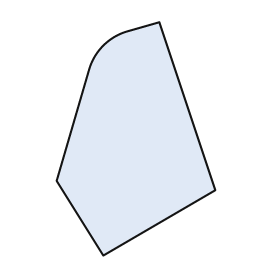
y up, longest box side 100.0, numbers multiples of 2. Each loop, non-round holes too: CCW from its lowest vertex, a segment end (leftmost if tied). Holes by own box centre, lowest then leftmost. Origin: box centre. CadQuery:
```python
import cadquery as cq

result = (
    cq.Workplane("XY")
    .moveTo(-14.0, -50.0)
    .lineTo(34.0, -22.0)
    .lineTo(10.0, 50.0)
    .lineTo(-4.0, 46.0)
    .threePointArc((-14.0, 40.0), (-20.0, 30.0))
    .lineTo(-34.0, -18.0)
    .close()
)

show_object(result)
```